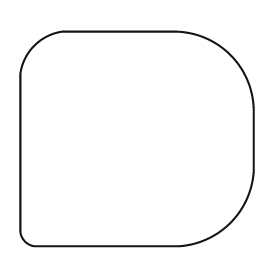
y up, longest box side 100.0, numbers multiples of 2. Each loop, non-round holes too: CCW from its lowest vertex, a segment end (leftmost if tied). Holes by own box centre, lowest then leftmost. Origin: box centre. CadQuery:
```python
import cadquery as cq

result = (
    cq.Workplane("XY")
    .moveTo(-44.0, -46.0)
    .lineTo(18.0, -46.0)
    .threePointArc((40.0, -36.0), (50.0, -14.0))
    .lineTo(50.0, 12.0)
    .threePointArc((40.0, 36.0), (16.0, 46.0))
    .lineTo(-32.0, 46.0)
    .threePointArc((-44.0, 40.0), (-50.0, 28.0))
    .lineTo(-50.0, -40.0)
    .threePointArc((-48.0, -44.0), (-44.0, -46.0))
    .close()
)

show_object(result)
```